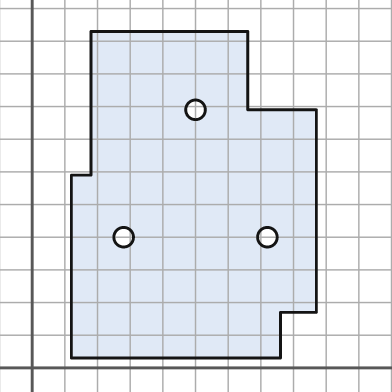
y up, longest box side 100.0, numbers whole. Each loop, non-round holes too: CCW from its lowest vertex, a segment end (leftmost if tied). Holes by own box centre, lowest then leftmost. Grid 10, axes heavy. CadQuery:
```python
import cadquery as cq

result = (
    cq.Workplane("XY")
    .moveTo(12.0, 3.0)
    .lineTo(76.0, 3.0)
    .lineTo(76.0, 17.0)
    .lineTo(87.0, 17.0)
    .lineTo(87.0, 79.0)
    .lineTo(66.0, 79.0)
    .lineTo(66.0, 103.0)
    .lineTo(18.0, 103.0)
    .lineTo(18.0, 59.0)
    .lineTo(12.0, 59.0)
    .close()
    .moveTo(28.0, 40.0)
    .circle(3.0)
    .moveTo(72.0, 40.0)
    .circle(3.0)
    .moveTo(50.0, 79.0)
    .circle(3.0)
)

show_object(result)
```